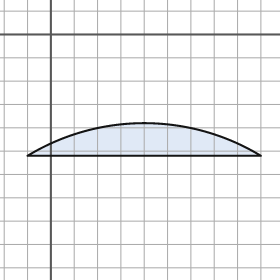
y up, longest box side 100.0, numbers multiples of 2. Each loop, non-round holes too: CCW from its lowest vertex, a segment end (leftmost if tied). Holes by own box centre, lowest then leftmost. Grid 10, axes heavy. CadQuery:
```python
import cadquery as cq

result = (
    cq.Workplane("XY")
    .moveTo(-10.0, -52.0)
    .lineTo(90.0, -52.0)
    .threePointArc((40.0, -38.0), (-10.0, -52.0))
    .close()
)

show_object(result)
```